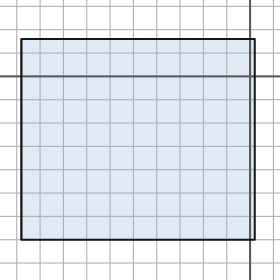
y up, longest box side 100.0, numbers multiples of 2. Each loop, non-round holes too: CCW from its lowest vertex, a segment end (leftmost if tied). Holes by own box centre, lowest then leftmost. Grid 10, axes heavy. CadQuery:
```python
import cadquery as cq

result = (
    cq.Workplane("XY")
    .moveTo(-98.0, -70.0)
    .lineTo(2.0, -70.0)
    .lineTo(2.0, 16.0)
    .lineTo(-98.0, 16.0)
    .close()
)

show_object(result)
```